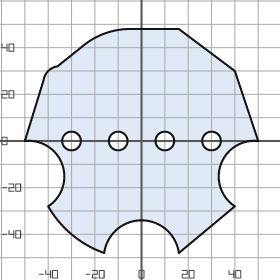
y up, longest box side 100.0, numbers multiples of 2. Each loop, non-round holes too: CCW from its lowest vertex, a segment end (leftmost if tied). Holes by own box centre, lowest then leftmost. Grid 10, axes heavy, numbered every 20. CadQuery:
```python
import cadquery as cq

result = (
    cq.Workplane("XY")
    .moveTo(-16.0, -48.0)
    .threePointArc((0.0, -34.0), (16.0, -48.0))
    .lineTo(40.0, -28.0)
    .threePointArc((34.0, -10.0), (50.0, 0.0))
    .lineTo(40.0, 30.0)
    .lineTo(16.0, 48.0)
    .lineTo(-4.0, 48.0)
    .threePointArc((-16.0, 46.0), (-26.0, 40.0))
    .lineTo(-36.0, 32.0)
    .threePointArc((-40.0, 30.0), (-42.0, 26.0))
    .lineTo(-50.0, 0.0)
    .threePointArc((-34.0, -10.0), (-40.0, -28.0))
    .threePointArc((-30.0, -40.0), (-16.0, -48.0))
    .close()
    .moveTo(-30.0, 0.0)
    .circle(4.0)
    .moveTo(-10.0, 0.0)
    .circle(4.0)
    .moveTo(10.0, 0.0)
    .circle(4.0)
    .moveTo(30.0, 0.0)
    .circle(4.0)
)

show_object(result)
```